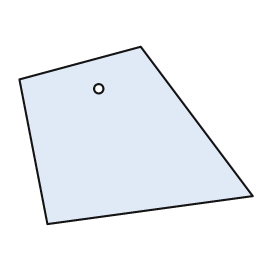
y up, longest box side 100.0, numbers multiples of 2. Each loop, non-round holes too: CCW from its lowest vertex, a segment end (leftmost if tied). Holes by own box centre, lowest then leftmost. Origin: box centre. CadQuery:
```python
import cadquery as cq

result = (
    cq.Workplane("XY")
    .moveTo(-38.0, -38.0)
    .lineTo(50.0, -26.0)
    .lineTo(2.0, 38.0)
    .lineTo(-50.0, 24.0)
    .close()
    .moveTo(-16.0, 20.0)
    .circle(2.0)
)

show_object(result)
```